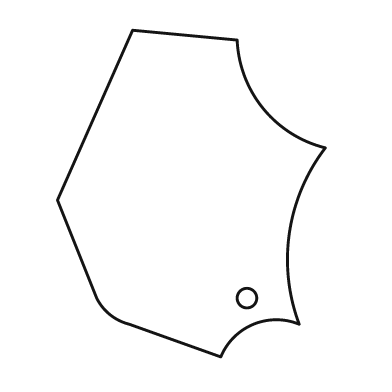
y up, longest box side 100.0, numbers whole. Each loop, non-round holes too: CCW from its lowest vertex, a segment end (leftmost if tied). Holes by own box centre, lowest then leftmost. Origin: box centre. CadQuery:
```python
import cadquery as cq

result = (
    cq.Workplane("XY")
    .moveTo(9.0, -50.0)
    .threePointArc((19.0, -40.0), (33.0, -40.0))
    .threePointArc((30.0, -12.0), (41.0, 14.0))
    .threePointArc((22.0, 26.0), (14.0, 47.0))
    .lineTo(-18.0, 50.0)
    .lineTo(-41.0, -2.0)
    .lineTo(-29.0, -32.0)
    .threePointArc((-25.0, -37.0), (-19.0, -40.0))
    .close()
    .moveTo(17.0, -32.0)
    .circle(3.0)
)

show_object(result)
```